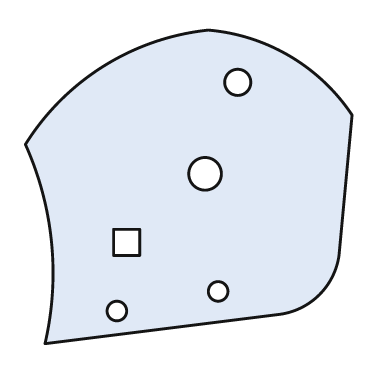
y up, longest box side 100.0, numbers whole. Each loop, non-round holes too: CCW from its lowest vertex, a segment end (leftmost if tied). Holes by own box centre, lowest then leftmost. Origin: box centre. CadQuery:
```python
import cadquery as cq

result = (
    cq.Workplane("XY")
    .moveTo(-44.0, -48.0)
    .lineTo(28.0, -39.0)
    .threePointArc((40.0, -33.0), (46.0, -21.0))
    .lineTo(50.0, 22.0)
    .threePointArc((31.0, 40.0), (6.0, 48.0))
    .threePointArc((-26.0, 37.0), (-50.0, 13.0))
    .threePointArc((-42.0, -17.0), (-44.0, -48.0))
    .close()
    .moveTo(-22.0, -38.0)
    .circle(3.0)
    .moveTo(9.0, -32.0)
    .circle(3.0)
    .moveTo(-23.0, -21.0)
    .lineTo(-15.0, -21.0)
    .lineTo(-15.0, -13.0)
    .lineTo(-23.0, -13.0)
    .close()
    .moveTo(5.0, 4.0)
    .circle(5.0)
    .moveTo(15.0, 32.0)
    .circle(4.0)
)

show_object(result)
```